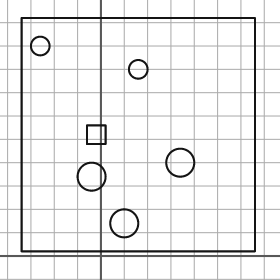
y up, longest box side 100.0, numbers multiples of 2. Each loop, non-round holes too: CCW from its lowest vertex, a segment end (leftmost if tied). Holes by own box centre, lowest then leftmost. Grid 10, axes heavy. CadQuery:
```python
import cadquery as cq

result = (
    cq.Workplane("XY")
    .moveTo(-34.0, 2.0)
    .lineTo(66.0, 2.0)
    .lineTo(66.0, 102.0)
    .lineTo(-34.0, 102.0)
    .close()
    .moveTo(10.0, 14.0)
    .circle(6.0)
    .moveTo(-4.0, 34.0)
    .circle(6.0)
    .moveTo(34.0, 40.0)
    .circle(6.0)
    .moveTo(-6.0, 48.0)
    .lineTo(2.0, 48.0)
    .lineTo(2.0, 56.0)
    .lineTo(-6.0, 56.0)
    .close()
    .moveTo(16.0, 80.0)
    .circle(4.0)
    .moveTo(-26.0, 90.0)
    .circle(4.0)
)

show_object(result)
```